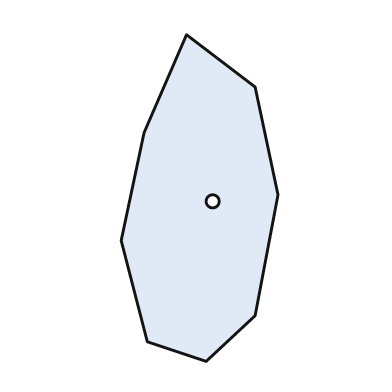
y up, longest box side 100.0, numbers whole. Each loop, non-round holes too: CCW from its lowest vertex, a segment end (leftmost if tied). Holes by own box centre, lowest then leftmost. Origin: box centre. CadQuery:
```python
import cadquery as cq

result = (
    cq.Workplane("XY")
    .moveTo(2.0, -50.0)
    .lineTo(17.0, -36.0)
    .lineTo(24.0, 1.0)
    .lineTo(17.0, 34.0)
    .lineTo(-4.0, 50.0)
    .lineTo(-17.0, 20.0)
    .lineTo(-24.0, -13.0)
    .lineTo(-16.0, -44.0)
    .close()
    .moveTo(4.0, -1.0)
    .circle(2.0)
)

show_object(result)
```